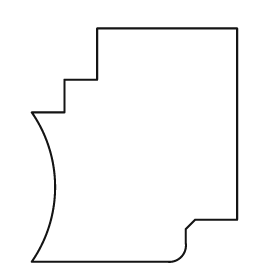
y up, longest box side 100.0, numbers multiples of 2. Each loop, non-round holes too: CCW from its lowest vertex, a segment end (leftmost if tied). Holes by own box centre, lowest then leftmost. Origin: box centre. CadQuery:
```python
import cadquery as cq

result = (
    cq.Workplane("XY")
    .moveTo(-44.0, -50.0)
    .lineTo(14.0, -50.0)
    .threePointArc((20.0, -48.0), (22.0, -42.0))
    .lineTo(22.0, -36.0)
    .lineTo(26.0, -32.0)
    .lineTo(44.0, -32.0)
    .lineTo(44.0, 50.0)
    .lineTo(-16.0, 50.0)
    .lineTo(-16.0, 28.0)
    .lineTo(-30.0, 28.0)
    .lineTo(-30.0, 14.0)
    .lineTo(-44.0, 14.0)
    .threePointArc((-34.0, -18.0), (-44.0, -50.0))
    .close()
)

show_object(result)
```